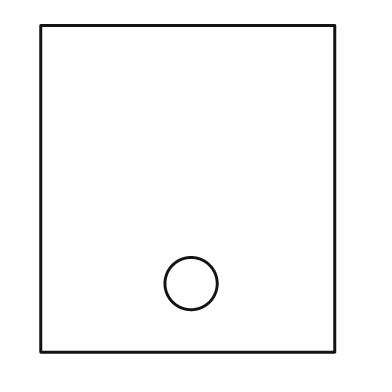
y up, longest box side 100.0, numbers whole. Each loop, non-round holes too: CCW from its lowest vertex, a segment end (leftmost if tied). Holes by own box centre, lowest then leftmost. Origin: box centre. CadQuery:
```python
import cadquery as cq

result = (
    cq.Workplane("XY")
    .moveTo(-45.0, -50.0)
    .lineTo(45.0, -50.0)
    .lineTo(45.0, 50.0)
    .lineTo(-45.0, 50.0)
    .close()
    .moveTo(1.0, -29.0)
    .circle(8.0)
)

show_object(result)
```